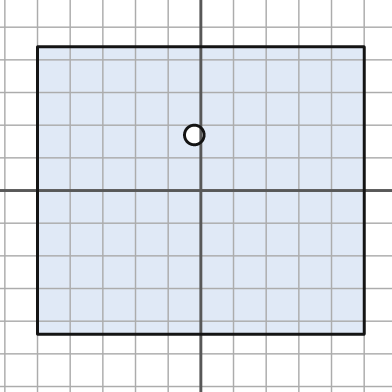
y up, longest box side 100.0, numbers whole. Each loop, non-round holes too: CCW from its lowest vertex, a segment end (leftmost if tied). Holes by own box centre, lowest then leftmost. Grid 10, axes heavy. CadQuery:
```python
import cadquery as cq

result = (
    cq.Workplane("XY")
    .moveTo(-50.0, -44.0)
    .lineTo(50.0, -44.0)
    .lineTo(50.0, 44.0)
    .lineTo(-50.0, 44.0)
    .close()
    .moveTo(-2.0, 17.0)
    .circle(3.0)
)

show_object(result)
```